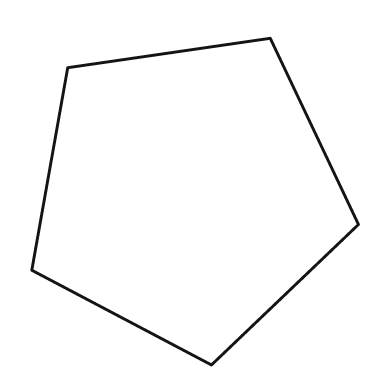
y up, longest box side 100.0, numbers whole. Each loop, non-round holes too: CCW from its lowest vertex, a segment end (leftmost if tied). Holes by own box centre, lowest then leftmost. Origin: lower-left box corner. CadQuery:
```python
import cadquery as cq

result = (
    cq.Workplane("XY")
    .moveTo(55.0, 0.0)
    .lineTo(100.0, 43.0)
    .lineTo(73.0, 100.0)
    .lineTo(11.0, 91.0)
    .lineTo(0.0, 29.0)
    .close()
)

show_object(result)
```